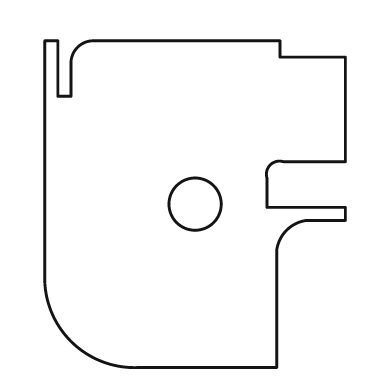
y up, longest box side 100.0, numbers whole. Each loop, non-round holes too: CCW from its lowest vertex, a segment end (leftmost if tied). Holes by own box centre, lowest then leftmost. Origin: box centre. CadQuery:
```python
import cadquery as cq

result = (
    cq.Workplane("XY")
    .moveTo(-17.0, -50.0)
    .lineTo(25.0, -50.0)
    .lineTo(25.0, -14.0)
    .threePointArc((28.0, -8.0), (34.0, -5.0))
    .lineTo(46.0, -5.0)
    .lineTo(46.0, -1.0)
    .lineTo(22.0, -1.0)
    .lineTo(22.0, 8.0)
    .threePointArc((23.0, 12.0), (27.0, 13.0))
    .lineTo(46.0, 13.0)
    .lineTo(46.0, 45.0)
    .lineTo(26.0, 45.0)
    .lineTo(26.0, 50.0)
    .lineTo(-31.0, 50.0)
    .threePointArc((-36.0, 48.0), (-38.0, 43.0))
    .lineTo(-38.0, 33.0)
    .lineTo(-42.0, 33.0)
    .lineTo(-42.0, 50.0)
    .lineTo(-46.0, 50.0)
    .lineTo(-46.0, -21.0)
    .threePointArc((-38.0, -42.0), (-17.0, -50.0))
    .close()
    .moveTo(0.0, 0.0)
    .circle(8.0)
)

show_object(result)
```